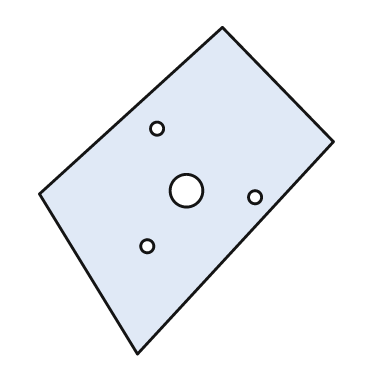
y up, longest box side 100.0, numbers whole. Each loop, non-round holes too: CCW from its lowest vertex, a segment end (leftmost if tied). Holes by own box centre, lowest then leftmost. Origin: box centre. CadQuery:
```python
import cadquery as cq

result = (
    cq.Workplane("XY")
    .moveTo(-15.0, -50.0)
    .lineTo(45.0, 15.0)
    .lineTo(11.0, 50.0)
    .lineTo(-45.0, -1.0)
    .close()
    .moveTo(-12.0, -17.0)
    .circle(2.0)
    .moveTo(21.0, -2.0)
    .circle(2.0)
    .moveTo(0.0, 0.0)
    .circle(5.0)
    .moveTo(-9.0, 19.0)
    .circle(2.0)
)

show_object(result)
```